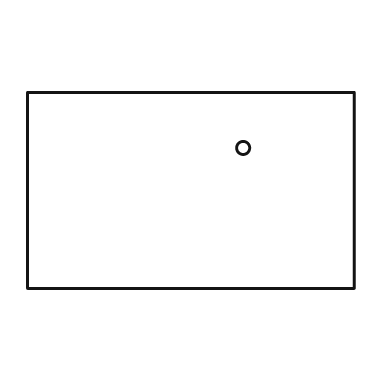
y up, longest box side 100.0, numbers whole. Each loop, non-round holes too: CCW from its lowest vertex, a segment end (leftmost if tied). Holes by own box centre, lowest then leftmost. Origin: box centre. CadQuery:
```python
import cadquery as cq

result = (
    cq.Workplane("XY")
    .moveTo(-50.0, -30.0)
    .lineTo(50.0, -30.0)
    .lineTo(50.0, 30.0)
    .lineTo(-50.0, 30.0)
    .close()
    .moveTo(16.0, 13.0)
    .circle(2.0)
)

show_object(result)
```